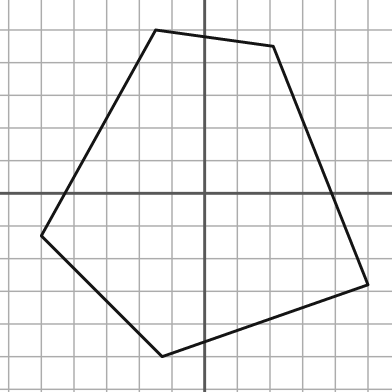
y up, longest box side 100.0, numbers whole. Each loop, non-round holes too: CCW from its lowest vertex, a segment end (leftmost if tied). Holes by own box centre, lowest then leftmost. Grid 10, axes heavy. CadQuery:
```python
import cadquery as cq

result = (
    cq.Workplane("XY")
    .moveTo(-13.0, -50.0)
    .lineTo(50.0, -28.0)
    .lineTo(21.0, 45.0)
    .lineTo(-15.0, 50.0)
    .lineTo(-50.0, -13.0)
    .close()
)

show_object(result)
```